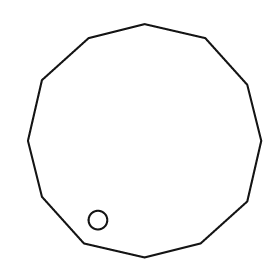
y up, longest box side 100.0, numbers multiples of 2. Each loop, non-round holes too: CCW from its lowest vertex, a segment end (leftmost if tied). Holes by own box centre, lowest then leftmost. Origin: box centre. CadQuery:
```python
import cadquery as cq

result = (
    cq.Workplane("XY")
    .moveTo(0.0, -50.0)
    .lineTo(24.0, -44.0)
    .lineTo(44.0, -26.0)
    .lineTo(50.0, 0.0)
    .lineTo(44.0, 24.0)
    .lineTo(26.0, 44.0)
    .lineTo(0.0, 50.0)
    .lineTo(-24.0, 44.0)
    .lineTo(-44.0, 26.0)
    .lineTo(-50.0, 0.0)
    .lineTo(-44.0, -24.0)
    .lineTo(-26.0, -44.0)
    .close()
    .moveTo(-20.0, -34.0)
    .circle(4.0)
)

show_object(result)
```